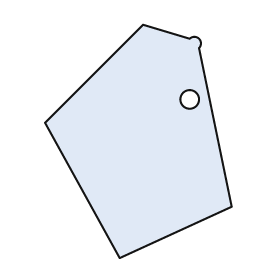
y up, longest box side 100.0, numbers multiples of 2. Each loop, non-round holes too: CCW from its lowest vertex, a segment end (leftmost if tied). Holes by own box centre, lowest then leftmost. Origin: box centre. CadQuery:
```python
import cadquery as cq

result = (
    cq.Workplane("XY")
    .moveTo(-8.0, -50.0)
    .lineTo(40.0, -28.0)
    .lineTo(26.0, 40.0)
    .threePointArc((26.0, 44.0), (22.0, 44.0))
    .lineTo(2.0, 50.0)
    .lineTo(-40.0, 8.0)
    .close()
    .moveTo(22.0, 18.0)
    .circle(4.0)
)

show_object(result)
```